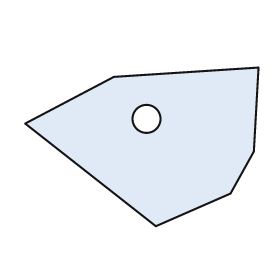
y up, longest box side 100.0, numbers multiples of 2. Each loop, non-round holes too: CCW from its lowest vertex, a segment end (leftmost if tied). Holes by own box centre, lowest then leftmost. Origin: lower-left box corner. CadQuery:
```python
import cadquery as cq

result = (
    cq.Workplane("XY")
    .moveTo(56.0, 0.0)
    .lineTo(88.0, 14.0)
    .lineTo(98.0, 32.0)
    .lineTo(100.0, 68.0)
    .lineTo(38.0, 64.0)
    .lineTo(0.0, 44.0)
    .close()
    .moveTo(52.0, 46.0)
    .circle(6.0)
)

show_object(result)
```